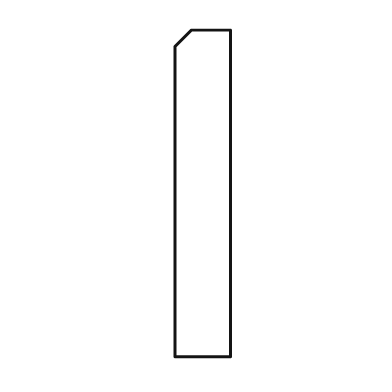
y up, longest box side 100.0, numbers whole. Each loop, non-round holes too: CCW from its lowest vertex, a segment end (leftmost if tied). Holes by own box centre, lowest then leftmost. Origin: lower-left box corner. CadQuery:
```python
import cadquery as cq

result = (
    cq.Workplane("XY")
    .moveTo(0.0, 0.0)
    .lineTo(17.0, 0.0)
    .lineTo(17.0, 100.0)
    .lineTo(5.0, 100.0)
    .lineTo(0.0, 95.0)
    .close()
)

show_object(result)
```